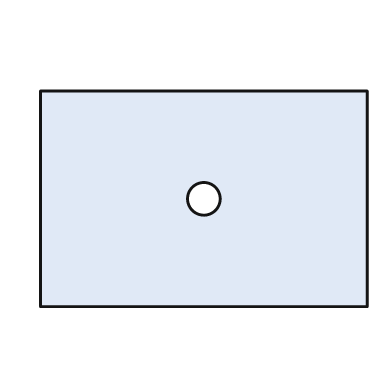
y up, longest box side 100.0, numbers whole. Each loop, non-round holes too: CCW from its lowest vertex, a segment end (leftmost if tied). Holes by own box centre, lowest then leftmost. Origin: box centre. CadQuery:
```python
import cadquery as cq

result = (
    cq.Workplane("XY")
    .moveTo(-50.0, -33.0)
    .lineTo(50.0, -33.0)
    .lineTo(50.0, 33.0)
    .lineTo(-50.0, 33.0)
    .close()
    .moveTo(0.0, 0.0)
    .circle(5.0)
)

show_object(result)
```